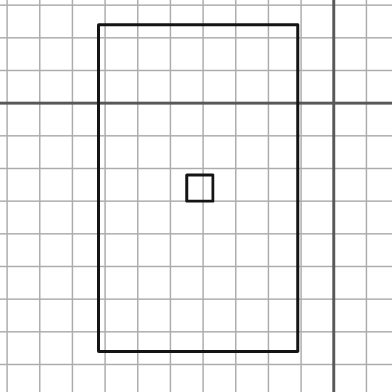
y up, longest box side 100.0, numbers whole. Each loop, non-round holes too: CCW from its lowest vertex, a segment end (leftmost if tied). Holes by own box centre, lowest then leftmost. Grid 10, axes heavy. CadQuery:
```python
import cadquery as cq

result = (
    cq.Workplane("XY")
    .moveTo(-72.0, -76.0)
    .lineTo(-11.0, -76.0)
    .lineTo(-11.0, 24.0)
    .lineTo(-72.0, 24.0)
    .close()
    .moveTo(-45.0, -30.0)
    .lineTo(-37.0, -30.0)
    .lineTo(-37.0, -22.0)
    .lineTo(-45.0, -22.0)
    .close()
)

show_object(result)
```